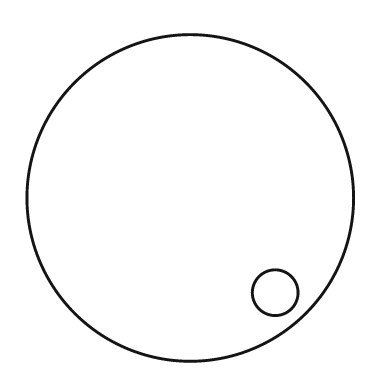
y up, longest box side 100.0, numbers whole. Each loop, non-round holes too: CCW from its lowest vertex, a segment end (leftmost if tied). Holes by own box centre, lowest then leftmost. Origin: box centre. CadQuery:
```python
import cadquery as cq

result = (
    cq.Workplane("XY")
    .moveTo(0.0, 0.0)
    .circle(50.0)
    .moveTo(26.0, -29.0)
    .circle(7.0)
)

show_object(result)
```